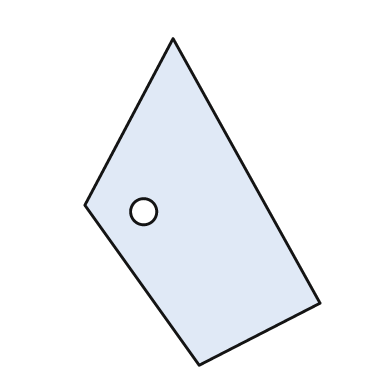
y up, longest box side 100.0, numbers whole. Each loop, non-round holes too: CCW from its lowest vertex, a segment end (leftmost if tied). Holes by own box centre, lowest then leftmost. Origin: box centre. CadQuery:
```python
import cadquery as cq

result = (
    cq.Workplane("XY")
    .moveTo(-1.0, -50.0)
    .lineTo(36.0, -31.0)
    .lineTo(-9.0, 50.0)
    .lineTo(-36.0, -1.0)
    .close()
    .moveTo(-18.0, -3.0)
    .circle(4.0)
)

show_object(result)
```